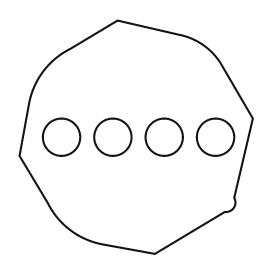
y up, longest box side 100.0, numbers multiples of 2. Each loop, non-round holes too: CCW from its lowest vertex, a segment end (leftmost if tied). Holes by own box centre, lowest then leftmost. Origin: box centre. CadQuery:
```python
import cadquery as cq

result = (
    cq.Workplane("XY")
    .moveTo(8.0, -50.0)
    .lineTo(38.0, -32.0)
    .threePointArc((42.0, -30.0), (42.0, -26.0))
    .lineTo(50.0, 8.0)
    .lineTo(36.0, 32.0)
    .threePointArc((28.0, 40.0), (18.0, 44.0))
    .lineTo(-8.0, 50.0)
    .lineTo(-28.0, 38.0)
    .threePointArc((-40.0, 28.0), (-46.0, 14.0))
    .lineTo(-50.0, -8.0)
    .lineTo(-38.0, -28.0)
    .threePointArc((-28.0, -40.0), (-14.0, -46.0))
    .close()
    .moveTo(-32.0, 0.0)
    .circle(8.0)
    .moveTo(-10.0, 0.0)
    .circle(8.0)
    .moveTo(12.0, 0.0)
    .circle(8.0)
    .moveTo(34.0, 0.0)
    .circle(8.0)
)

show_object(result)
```